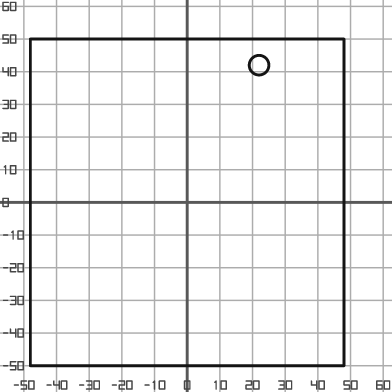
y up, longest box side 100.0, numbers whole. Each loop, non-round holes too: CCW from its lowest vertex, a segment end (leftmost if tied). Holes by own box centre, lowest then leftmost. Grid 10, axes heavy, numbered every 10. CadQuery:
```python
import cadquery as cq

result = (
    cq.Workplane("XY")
    .moveTo(-48.0, -50.0)
    .lineTo(48.0, -50.0)
    .lineTo(48.0, 50.0)
    .lineTo(-48.0, 50.0)
    .close()
    .moveTo(22.0, 42.0)
    .circle(3.0)
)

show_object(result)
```